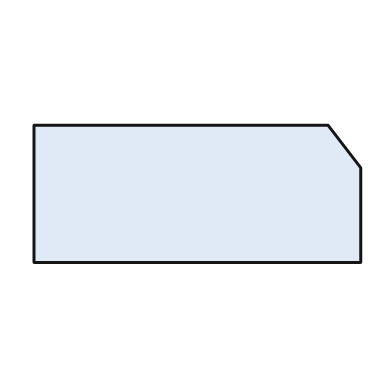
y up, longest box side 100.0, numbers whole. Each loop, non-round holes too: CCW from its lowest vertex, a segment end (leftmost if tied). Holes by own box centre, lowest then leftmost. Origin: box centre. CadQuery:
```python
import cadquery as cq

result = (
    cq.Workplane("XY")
    .moveTo(-50.0, -21.0)
    .lineTo(50.0, -21.0)
    .lineTo(50.0, 8.0)
    .lineTo(40.0, 21.0)
    .lineTo(-50.0, 21.0)
    .close()
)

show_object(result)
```